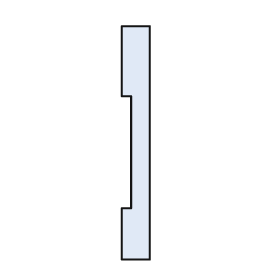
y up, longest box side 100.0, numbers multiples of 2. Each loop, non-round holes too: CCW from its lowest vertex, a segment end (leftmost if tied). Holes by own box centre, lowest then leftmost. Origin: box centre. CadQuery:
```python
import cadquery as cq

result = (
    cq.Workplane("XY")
    .moveTo(-6.0, -50.0)
    .lineTo(6.0, -50.0)
    .lineTo(6.0, 50.0)
    .lineTo(-6.0, 50.0)
    .lineTo(-6.0, 20.0)
    .lineTo(-2.0, 20.0)
    .lineTo(-2.0, -28.0)
    .lineTo(-6.0, -28.0)
    .close()
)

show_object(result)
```